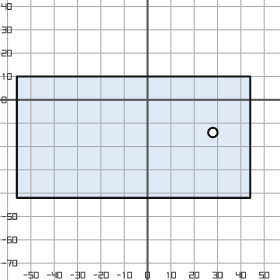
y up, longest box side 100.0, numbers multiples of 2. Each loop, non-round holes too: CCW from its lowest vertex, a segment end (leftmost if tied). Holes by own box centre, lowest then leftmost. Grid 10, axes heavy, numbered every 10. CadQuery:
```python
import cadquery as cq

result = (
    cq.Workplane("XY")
    .moveTo(-56.0, -42.0)
    .lineTo(44.0, -42.0)
    .lineTo(44.0, 10.0)
    .lineTo(-56.0, 10.0)
    .close()
    .moveTo(28.0, -14.0)
    .circle(2.0)
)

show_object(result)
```